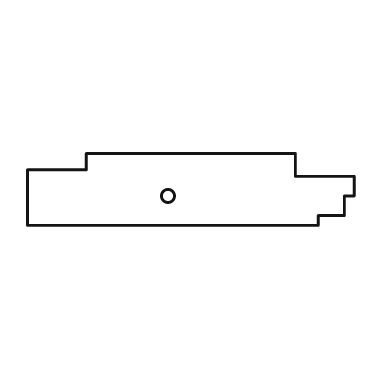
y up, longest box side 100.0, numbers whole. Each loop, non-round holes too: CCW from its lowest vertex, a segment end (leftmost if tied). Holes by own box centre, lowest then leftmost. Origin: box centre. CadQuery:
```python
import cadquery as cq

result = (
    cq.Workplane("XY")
    .moveTo(-50.0, -11.0)
    .lineTo(39.0, -11.0)
    .lineTo(39.0, -8.0)
    .lineTo(47.0, -8.0)
    .lineTo(47.0, -2.0)
    .lineTo(50.0, -2.0)
    .lineTo(50.0, 4.0)
    .lineTo(32.0, 4.0)
    .lineTo(32.0, 11.0)
    .lineTo(-32.0, 11.0)
    .lineTo(-32.0, 6.0)
    .lineTo(-50.0, 6.0)
    .close()
    .moveTo(-7.0, -2.0)
    .circle(2.0)
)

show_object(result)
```